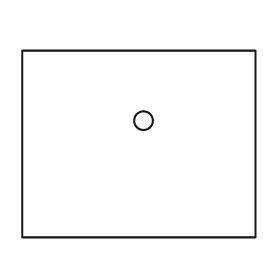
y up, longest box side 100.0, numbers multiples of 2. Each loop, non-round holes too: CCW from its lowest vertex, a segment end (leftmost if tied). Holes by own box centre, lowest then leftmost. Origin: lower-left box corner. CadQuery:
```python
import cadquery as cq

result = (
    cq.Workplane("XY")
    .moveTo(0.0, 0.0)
    .lineTo(100.0, 0.0)
    .lineTo(100.0, 80.0)
    .lineTo(0.0, 80.0)
    .close()
    .moveTo(52.0, 50.0)
    .circle(4.0)
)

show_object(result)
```